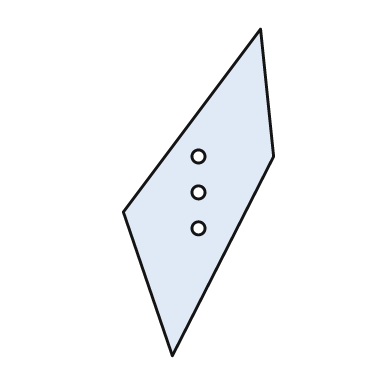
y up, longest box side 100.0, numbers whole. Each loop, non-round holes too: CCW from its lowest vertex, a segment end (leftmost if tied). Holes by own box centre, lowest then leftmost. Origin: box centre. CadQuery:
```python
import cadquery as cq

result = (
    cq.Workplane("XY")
    .moveTo(-8.0, -50.0)
    .lineTo(23.0, 11.0)
    .lineTo(19.0, 50.0)
    .lineTo(-23.0, -6.0)
    .close()
    .moveTo(0.0, -11.0)
    .circle(2.0)
    .moveTo(0.0, 0.0)
    .circle(2.0)
    .moveTo(0.0, 11.0)
    .circle(2.0)
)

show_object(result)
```